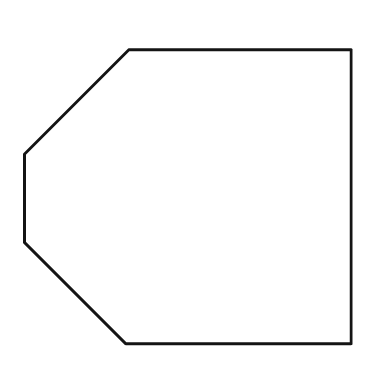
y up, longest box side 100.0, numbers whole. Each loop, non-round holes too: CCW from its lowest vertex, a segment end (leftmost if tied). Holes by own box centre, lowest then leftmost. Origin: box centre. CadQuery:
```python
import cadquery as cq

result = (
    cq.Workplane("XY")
    .moveTo(-19.0, -45.0)
    .lineTo(50.0, -45.0)
    .lineTo(50.0, 45.0)
    .lineTo(-18.0, 45.0)
    .lineTo(-50.0, 13.0)
    .lineTo(-50.0, -14.0)
    .close()
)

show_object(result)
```